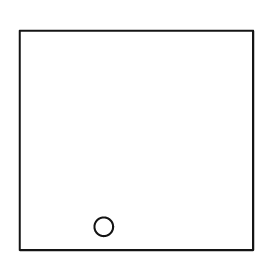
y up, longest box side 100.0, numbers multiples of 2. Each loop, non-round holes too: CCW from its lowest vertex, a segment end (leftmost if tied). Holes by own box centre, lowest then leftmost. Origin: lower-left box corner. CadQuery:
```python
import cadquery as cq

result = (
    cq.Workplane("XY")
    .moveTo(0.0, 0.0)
    .lineTo(100.0, 0.0)
    .lineTo(100.0, 94.0)
    .lineTo(0.0, 94.0)
    .close()
    .moveTo(36.0, 10.0)
    .circle(4.0)
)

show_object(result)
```